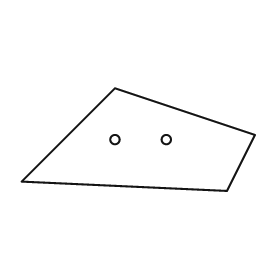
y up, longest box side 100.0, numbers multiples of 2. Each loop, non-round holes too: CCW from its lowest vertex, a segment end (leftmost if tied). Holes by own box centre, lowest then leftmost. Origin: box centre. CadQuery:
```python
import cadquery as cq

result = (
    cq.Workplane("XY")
    .moveTo(38.0, -22.0)
    .lineTo(50.0, 2.0)
    .lineTo(-10.0, 22.0)
    .lineTo(-50.0, -18.0)
    .close()
    .moveTo(-10.0, 0.0)
    .circle(2.0)
    .moveTo(12.0, 0.0)
    .circle(2.0)
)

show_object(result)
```